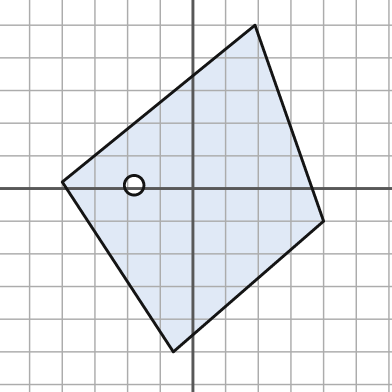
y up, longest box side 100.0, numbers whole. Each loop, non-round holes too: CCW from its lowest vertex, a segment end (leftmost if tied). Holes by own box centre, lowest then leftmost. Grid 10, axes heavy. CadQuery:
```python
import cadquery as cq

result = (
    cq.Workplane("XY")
    .moveTo(-6.0, -50.0)
    .lineTo(40.0, -10.0)
    .lineTo(19.0, 50.0)
    .lineTo(-40.0, 2.0)
    .close()
    .moveTo(-18.0, 1.0)
    .circle(3.0)
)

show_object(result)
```